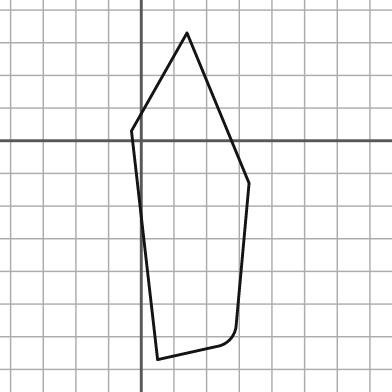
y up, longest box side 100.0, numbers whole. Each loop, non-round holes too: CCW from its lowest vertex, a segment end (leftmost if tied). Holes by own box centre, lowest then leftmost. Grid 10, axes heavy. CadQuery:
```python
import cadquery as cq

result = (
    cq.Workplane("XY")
    .moveTo(5.0, -67.0)
    .lineTo(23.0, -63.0)
    .threePointArc((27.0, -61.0), (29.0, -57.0))
    .lineTo(33.0, -13.0)
    .lineTo(14.0, 33.0)
    .lineTo(-3.0, 3.0)
    .close()
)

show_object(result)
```